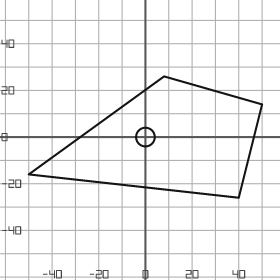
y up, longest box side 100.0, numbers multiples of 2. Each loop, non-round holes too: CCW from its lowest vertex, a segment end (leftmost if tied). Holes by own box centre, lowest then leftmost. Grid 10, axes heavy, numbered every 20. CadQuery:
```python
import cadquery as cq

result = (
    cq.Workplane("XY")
    .moveTo(40.0, -26.0)
    .lineTo(50.0, 14.0)
    .lineTo(8.0, 26.0)
    .lineTo(-50.0, -16.0)
    .close()
    .moveTo(0.0, 0.0)
    .circle(4.0)
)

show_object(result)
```